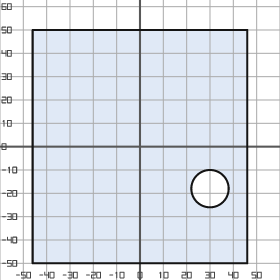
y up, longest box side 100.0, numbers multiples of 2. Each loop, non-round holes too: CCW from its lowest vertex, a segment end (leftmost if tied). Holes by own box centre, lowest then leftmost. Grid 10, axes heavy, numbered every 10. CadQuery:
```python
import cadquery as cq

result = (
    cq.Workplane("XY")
    .moveTo(-46.0, -50.0)
    .lineTo(46.0, -50.0)
    .lineTo(46.0, 50.0)
    .lineTo(-46.0, 50.0)
    .close()
    .moveTo(30.0, -18.0)
    .circle(8.0)
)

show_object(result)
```